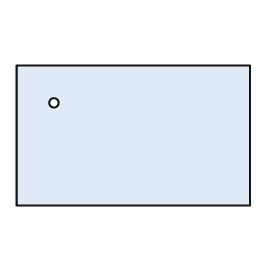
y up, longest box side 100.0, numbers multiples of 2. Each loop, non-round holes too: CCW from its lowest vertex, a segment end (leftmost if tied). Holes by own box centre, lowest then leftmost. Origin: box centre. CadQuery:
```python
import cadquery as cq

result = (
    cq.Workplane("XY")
    .moveTo(-50.0, -30.0)
    .lineTo(50.0, -30.0)
    .lineTo(50.0, 30.0)
    .lineTo(-50.0, 30.0)
    .close()
    .moveTo(-34.0, 14.0)
    .circle(2.0)
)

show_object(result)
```